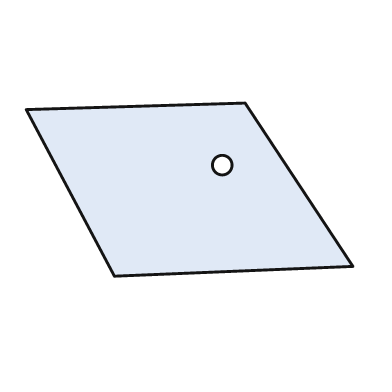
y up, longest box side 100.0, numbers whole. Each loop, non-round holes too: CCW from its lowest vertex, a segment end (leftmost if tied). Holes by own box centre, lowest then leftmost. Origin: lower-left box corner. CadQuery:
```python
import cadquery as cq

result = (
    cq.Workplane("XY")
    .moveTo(27.0, 0.0)
    .lineTo(100.0, 3.0)
    .lineTo(67.0, 53.0)
    .lineTo(0.0, 51.0)
    .close()
    .moveTo(60.0, 34.0)
    .circle(3.0)
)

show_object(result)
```